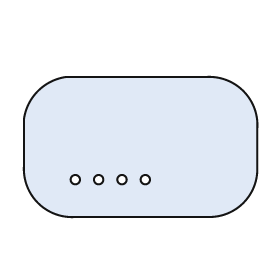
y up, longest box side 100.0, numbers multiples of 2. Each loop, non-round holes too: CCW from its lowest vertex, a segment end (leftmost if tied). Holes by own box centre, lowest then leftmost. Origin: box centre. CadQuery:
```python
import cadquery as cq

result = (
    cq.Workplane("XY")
    .moveTo(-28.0, -30.0)
    .lineTo(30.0, -30.0)
    .threePointArc((44.0, -24.0), (50.0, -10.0))
    .lineTo(50.0, 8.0)
    .threePointArc((44.0, 24.0), (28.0, 30.0))
    .lineTo(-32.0, 30.0)
    .threePointArc((-44.0, 24.0), (-50.0, 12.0))
    .lineTo(-50.0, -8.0)
    .threePointArc((-44.0, -24.0), (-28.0, -30.0))
    .close()
    .moveTo(-28.0, -14.0)
    .circle(2.0)
    .moveTo(-18.0, -14.0)
    .circle(2.0)
    .moveTo(-8.0, -14.0)
    .circle(2.0)
    .moveTo(2.0, -14.0)
    .circle(2.0)
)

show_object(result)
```